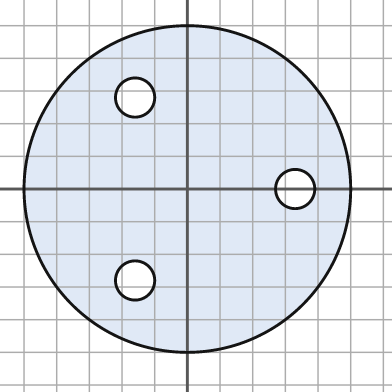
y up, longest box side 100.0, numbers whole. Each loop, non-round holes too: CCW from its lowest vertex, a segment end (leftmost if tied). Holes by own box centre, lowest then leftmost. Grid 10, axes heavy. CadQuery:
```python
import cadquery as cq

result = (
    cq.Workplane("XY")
    .moveTo(0.0, 0.0)
    .circle(50.0)
    .moveTo(-16.0, -28.0)
    .circle(6.0)
    .moveTo(33.0, 0.0)
    .circle(6.0)
    .moveTo(-16.0, 28.0)
    .circle(6.0)
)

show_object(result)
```